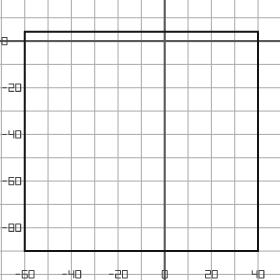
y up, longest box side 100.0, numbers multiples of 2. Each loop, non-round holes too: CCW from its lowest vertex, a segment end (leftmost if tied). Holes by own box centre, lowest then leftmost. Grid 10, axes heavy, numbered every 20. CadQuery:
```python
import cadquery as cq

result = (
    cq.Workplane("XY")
    .moveTo(-60.0, -90.0)
    .lineTo(40.0, -90.0)
    .lineTo(40.0, 4.0)
    .lineTo(-60.0, 4.0)
    .close()
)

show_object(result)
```